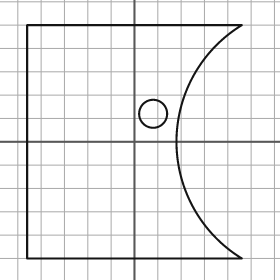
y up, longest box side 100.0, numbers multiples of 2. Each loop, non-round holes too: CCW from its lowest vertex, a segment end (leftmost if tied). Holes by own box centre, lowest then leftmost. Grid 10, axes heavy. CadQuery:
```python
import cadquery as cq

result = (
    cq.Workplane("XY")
    .moveTo(-46.0, -50.0)
    .lineTo(46.0, -50.0)
    .threePointArc((18.0, 0.0), (46.0, 50.0))
    .lineTo(-46.0, 50.0)
    .close()
    .moveTo(8.0, 12.0)
    .circle(6.0)
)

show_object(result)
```